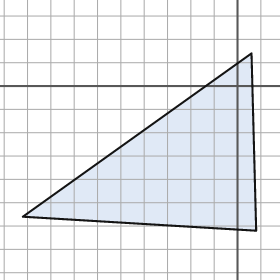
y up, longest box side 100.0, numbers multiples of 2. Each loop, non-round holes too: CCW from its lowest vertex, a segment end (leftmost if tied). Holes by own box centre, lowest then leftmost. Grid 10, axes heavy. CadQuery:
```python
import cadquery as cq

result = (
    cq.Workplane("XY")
    .moveTo(8.0, -62.0)
    .lineTo(6.0, 14.0)
    .lineTo(-92.0, -56.0)
    .close()
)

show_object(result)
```